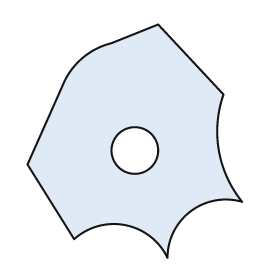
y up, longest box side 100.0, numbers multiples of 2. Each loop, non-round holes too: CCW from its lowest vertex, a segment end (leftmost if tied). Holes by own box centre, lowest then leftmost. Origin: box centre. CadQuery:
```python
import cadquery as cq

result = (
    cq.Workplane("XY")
    .moveTo(14.0, -50.0)
    .threePointArc((24.0, -30.0), (46.0, -26.0))
    .threePointArc((36.0, -4.0), (38.0, 20.0))
    .lineTo(10.0, 50.0)
    .lineTo(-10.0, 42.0)
    .threePointArc((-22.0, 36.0), (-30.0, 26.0))
    .lineTo(-46.0, -10.0)
    .lineTo(-26.0, -42.0)
    .threePointArc((-4.0, -36.0), (14.0, -50.0))
    .close()
    .moveTo(0.0, -4.0)
    .circle(10.0)
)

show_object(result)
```